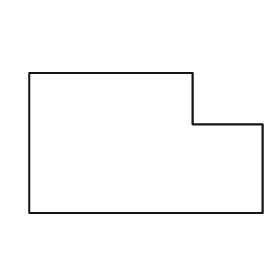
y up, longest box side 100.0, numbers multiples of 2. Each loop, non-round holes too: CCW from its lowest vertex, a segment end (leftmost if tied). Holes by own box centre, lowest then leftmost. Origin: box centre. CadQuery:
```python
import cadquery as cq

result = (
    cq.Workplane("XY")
    .moveTo(-50.0, -30.0)
    .lineTo(50.0, -30.0)
    .lineTo(50.0, 8.0)
    .lineTo(20.0, 8.0)
    .lineTo(20.0, 30.0)
    .lineTo(-50.0, 30.0)
    .close()
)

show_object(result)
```